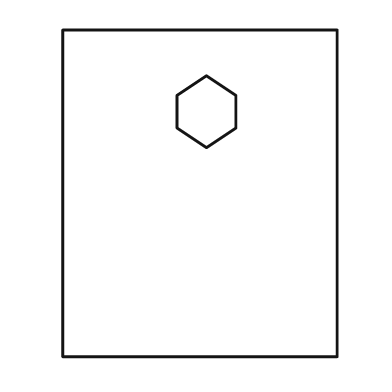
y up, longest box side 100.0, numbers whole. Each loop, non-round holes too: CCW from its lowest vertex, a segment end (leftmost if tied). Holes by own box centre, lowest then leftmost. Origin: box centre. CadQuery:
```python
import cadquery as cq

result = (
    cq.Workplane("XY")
    .moveTo(-42.0, -50.0)
    .lineTo(42.0, -50.0)
    .lineTo(42.0, 50.0)
    .lineTo(-42.0, 50.0)
    .close()
    .moveTo(2.0, 14.0)
    .lineTo(11.0, 20.0)
    .lineTo(11.0, 30.0)
    .lineTo(2.0, 36.0)
    .lineTo(-7.0, 30.0)
    .lineTo(-7.0, 20.0)
    .close()
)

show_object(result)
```